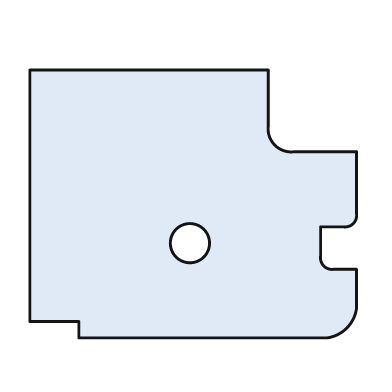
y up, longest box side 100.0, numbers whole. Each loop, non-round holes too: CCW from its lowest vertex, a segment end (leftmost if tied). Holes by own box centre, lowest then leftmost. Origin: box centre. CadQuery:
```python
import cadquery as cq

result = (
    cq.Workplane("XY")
    .moveTo(-35.0, -41.0)
    .lineTo(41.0, -41.0)
    .threePointArc((47.0, -38.0), (50.0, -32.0))
    .lineTo(50.0, -20.0)
    .lineTo(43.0, -20.0)
    .threePointArc((40.0, -19.0), (39.0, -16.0))
    .lineTo(39.0, -7.0)
    .lineTo(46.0, -7.0)
    .threePointArc((49.0, -6.0), (50.0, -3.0))
    .lineTo(50.0, 16.0)
    .lineTo(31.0, 16.0)
    .threePointArc((25.0, 18.0), (23.0, 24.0))
    .lineTo(23.0, 41.0)
    .lineTo(-50.0, 41.0)
    .lineTo(-50.0, -36.0)
    .lineTo(-35.0, -36.0)
    .close()
    .moveTo(-1.0, -12.0)
    .circle(6.0)
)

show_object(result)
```